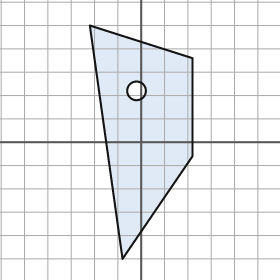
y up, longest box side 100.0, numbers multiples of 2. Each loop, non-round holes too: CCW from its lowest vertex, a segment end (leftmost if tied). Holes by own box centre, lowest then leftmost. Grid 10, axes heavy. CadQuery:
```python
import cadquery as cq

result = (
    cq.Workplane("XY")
    .moveTo(-8.0, -50.0)
    .lineTo(22.0, -6.0)
    .lineTo(22.0, 36.0)
    .lineTo(-22.0, 50.0)
    .close()
    .moveTo(-2.0, 22.0)
    .circle(4.0)
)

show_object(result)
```